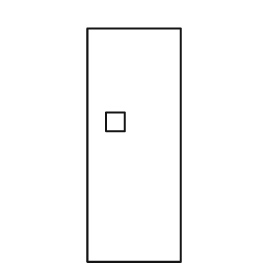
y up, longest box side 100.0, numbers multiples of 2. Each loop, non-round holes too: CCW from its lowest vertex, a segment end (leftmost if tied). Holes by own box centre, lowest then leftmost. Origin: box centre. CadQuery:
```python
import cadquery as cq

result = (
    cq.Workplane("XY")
    .moveTo(-20.0, -50.0)
    .lineTo(20.0, -50.0)
    .lineTo(20.0, 50.0)
    .lineTo(-20.0, 50.0)
    .close()
    .moveTo(-12.0, 6.0)
    .lineTo(-4.0, 6.0)
    .lineTo(-4.0, 14.0)
    .lineTo(-12.0, 14.0)
    .close()
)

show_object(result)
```